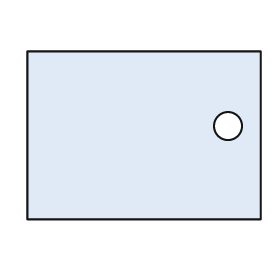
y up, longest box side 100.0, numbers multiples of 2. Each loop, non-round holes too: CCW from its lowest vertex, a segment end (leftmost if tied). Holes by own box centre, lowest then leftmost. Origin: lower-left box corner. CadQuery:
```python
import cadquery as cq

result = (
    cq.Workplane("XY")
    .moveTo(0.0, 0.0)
    .lineTo(100.0, 0.0)
    .lineTo(100.0, 72.0)
    .lineTo(0.0, 72.0)
    .close()
    .moveTo(86.0, 40.0)
    .circle(6.0)
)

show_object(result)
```